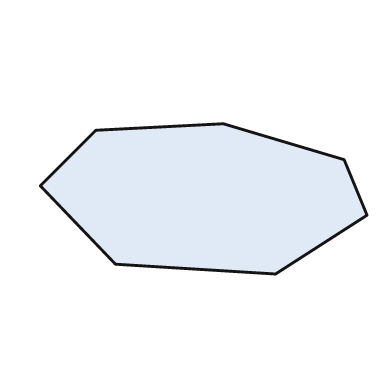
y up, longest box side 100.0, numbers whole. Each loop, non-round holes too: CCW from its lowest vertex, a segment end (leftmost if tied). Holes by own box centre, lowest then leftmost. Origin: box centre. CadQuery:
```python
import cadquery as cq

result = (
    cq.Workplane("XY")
    .moveTo(22.0, -23.0)
    .lineTo(50.0, -5.0)
    .lineTo(43.0, 12.0)
    .lineTo(6.0, 23.0)
    .lineTo(-33.0, 21.0)
    .lineTo(-50.0, 4.0)
    .lineTo(-27.0, -20.0)
    .close()
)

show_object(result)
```